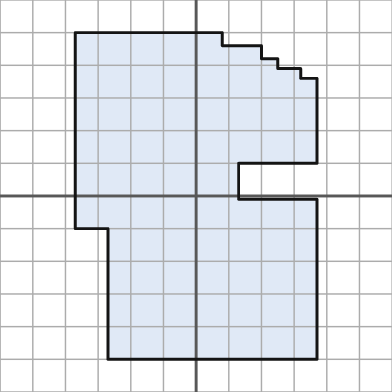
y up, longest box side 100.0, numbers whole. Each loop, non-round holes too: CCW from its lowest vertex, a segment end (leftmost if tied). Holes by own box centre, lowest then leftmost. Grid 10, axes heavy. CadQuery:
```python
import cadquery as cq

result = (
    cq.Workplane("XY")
    .moveTo(-27.0, -50.0)
    .lineTo(37.0, -50.0)
    .lineTo(37.0, -1.0)
    .lineTo(13.0, -1.0)
    .lineTo(13.0, 10.0)
    .lineTo(37.0, 10.0)
    .lineTo(37.0, 36.0)
    .lineTo(32.0, 36.0)
    .lineTo(32.0, 39.0)
    .lineTo(25.0, 39.0)
    .lineTo(25.0, 42.0)
    .lineTo(20.0, 42.0)
    .lineTo(20.0, 46.0)
    .lineTo(8.0, 46.0)
    .lineTo(8.0, 50.0)
    .lineTo(-37.0, 50.0)
    .lineTo(-37.0, -10.0)
    .lineTo(-27.0, -10.0)
    .close()
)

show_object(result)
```